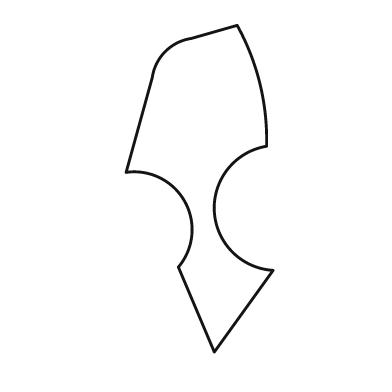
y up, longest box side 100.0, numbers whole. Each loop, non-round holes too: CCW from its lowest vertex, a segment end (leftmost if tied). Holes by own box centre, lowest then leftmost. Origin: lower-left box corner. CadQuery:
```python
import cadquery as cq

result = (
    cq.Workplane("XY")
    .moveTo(27.0, 0.0)
    .lineTo(45.0, 25.0)
    .threePointArc((27.0, 43.0), (43.0, 63.0))
    .threePointArc((41.0, 82.0), (34.0, 100.0))
    .lineTo(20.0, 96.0)
    .threePointArc((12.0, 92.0), (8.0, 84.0))
    .lineTo(0.0, 55.0)
    .threePointArc((18.0, 46.0), (16.0, 26.0))
    .close()
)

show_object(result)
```